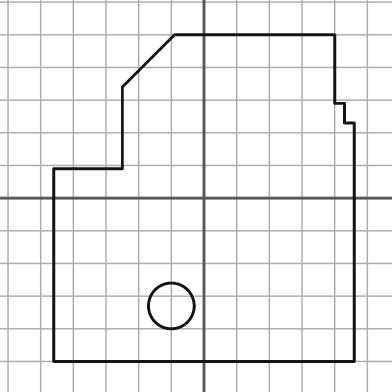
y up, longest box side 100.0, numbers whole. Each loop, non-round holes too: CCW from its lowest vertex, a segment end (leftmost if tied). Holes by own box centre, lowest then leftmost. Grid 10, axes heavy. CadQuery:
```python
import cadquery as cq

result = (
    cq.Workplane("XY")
    .moveTo(-46.0, -50.0)
    .lineTo(46.0, -50.0)
    .lineTo(46.0, 23.0)
    .lineTo(43.0, 23.0)
    .lineTo(43.0, 29.0)
    .lineTo(40.0, 29.0)
    .lineTo(40.0, 50.0)
    .lineTo(-9.0, 50.0)
    .lineTo(-25.0, 34.0)
    .lineTo(-25.0, 9.0)
    .lineTo(-46.0, 9.0)
    .close()
    .moveTo(-10.0, -33.0)
    .circle(7.0)
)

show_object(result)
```